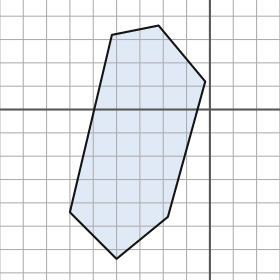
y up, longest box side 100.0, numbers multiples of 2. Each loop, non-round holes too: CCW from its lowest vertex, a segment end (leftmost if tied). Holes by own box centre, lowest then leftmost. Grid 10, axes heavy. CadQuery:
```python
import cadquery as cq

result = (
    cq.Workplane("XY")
    .moveTo(-40.0, -64.0)
    .lineTo(-18.0, -46.0)
    .lineTo(-2.0, 12.0)
    .lineTo(-22.0, 36.0)
    .lineTo(-42.0, 32.0)
    .lineTo(-60.0, -44.0)
    .close()
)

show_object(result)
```